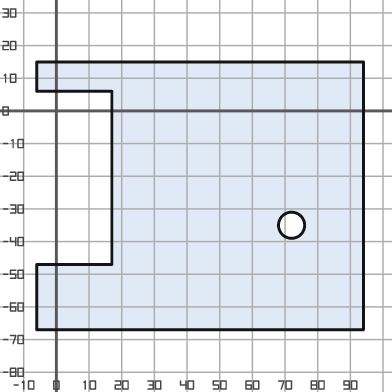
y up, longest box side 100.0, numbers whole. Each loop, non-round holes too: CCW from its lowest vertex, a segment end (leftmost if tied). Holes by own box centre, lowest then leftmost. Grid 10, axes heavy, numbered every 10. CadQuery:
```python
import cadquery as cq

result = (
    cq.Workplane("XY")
    .moveTo(-6.0, -67.0)
    .lineTo(94.0, -67.0)
    .lineTo(94.0, 15.0)
    .lineTo(-6.0, 15.0)
    .lineTo(-6.0, 6.0)
    .lineTo(17.0, 6.0)
    .lineTo(17.0, -47.0)
    .lineTo(-6.0, -47.0)
    .close()
    .moveTo(72.0, -35.0)
    .circle(4.0)
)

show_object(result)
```